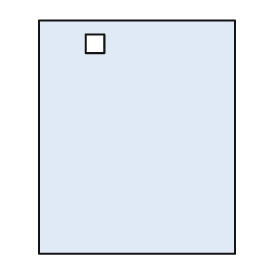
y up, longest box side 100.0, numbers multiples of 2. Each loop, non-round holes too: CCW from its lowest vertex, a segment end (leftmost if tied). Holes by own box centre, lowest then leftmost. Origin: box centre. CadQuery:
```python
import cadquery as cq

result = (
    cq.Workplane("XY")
    .moveTo(-42.0, -50.0)
    .lineTo(42.0, -50.0)
    .lineTo(42.0, 50.0)
    .lineTo(-42.0, 50.0)
    .close()
    .moveTo(-22.0, 36.0)
    .lineTo(-14.0, 36.0)
    .lineTo(-14.0, 44.0)
    .lineTo(-22.0, 44.0)
    .close()
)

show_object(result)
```